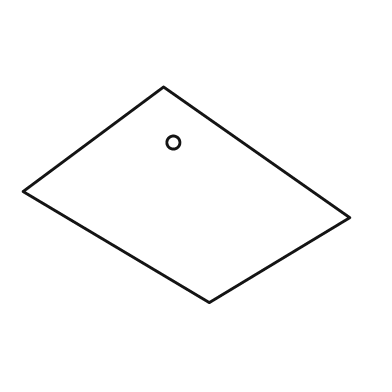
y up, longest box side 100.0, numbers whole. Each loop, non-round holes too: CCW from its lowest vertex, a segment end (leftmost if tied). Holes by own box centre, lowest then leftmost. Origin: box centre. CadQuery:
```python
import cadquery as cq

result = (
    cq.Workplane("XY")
    .moveTo(7.0, -33.0)
    .lineTo(50.0, -7.0)
    .lineTo(-7.0, 33.0)
    .lineTo(-50.0, 1.0)
    .close()
    .moveTo(-4.0, 16.0)
    .circle(2.0)
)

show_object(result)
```